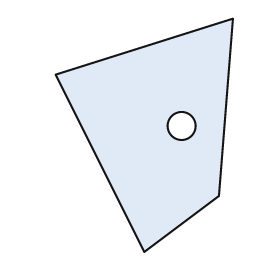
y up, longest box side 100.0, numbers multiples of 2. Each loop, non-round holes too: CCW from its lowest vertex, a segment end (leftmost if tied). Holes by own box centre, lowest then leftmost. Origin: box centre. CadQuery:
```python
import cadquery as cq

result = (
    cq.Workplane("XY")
    .moveTo(0.0, -50.0)
    .lineTo(32.0, -26.0)
    .lineTo(38.0, 50.0)
    .lineTo(-38.0, 26.0)
    .close()
    .moveTo(16.0, 4.0)
    .circle(6.0)
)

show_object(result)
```